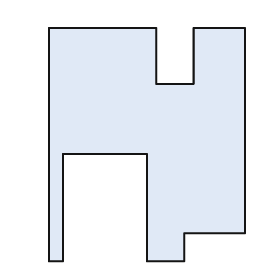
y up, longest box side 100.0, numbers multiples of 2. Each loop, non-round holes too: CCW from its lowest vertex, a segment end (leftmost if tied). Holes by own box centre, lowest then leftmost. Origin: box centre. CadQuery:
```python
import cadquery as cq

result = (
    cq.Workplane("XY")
    .moveTo(-42.0, -50.0)
    .lineTo(-36.0, -50.0)
    .lineTo(-36.0, -4.0)
    .lineTo(0.0, -4.0)
    .lineTo(0.0, -50.0)
    .lineTo(16.0, -50.0)
    .lineTo(16.0, -38.0)
    .lineTo(42.0, -38.0)
    .lineTo(42.0, 50.0)
    .lineTo(20.0, 50.0)
    .lineTo(20.0, 26.0)
    .lineTo(4.0, 26.0)
    .lineTo(4.0, 50.0)
    .lineTo(-42.0, 50.0)
    .close()
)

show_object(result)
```